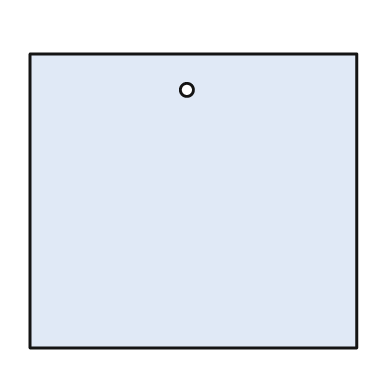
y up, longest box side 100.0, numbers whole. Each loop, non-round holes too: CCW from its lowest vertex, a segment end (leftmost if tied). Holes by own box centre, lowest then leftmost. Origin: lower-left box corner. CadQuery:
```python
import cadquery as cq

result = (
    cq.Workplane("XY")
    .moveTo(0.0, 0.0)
    .lineTo(100.0, 0.0)
    .lineTo(100.0, 90.0)
    .lineTo(0.0, 90.0)
    .close()
    .moveTo(48.0, 79.0)
    .circle(2.0)
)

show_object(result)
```